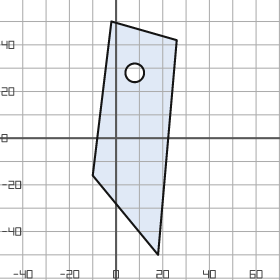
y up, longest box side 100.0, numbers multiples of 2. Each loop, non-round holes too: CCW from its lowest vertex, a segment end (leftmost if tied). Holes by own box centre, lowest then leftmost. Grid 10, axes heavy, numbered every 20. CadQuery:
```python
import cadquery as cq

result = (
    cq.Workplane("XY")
    .moveTo(18.0, -50.0)
    .lineTo(26.0, 42.0)
    .lineTo(-2.0, 50.0)
    .lineTo(-10.0, -16.0)
    .close()
    .moveTo(8.0, 28.0)
    .circle(4.0)
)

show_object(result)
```